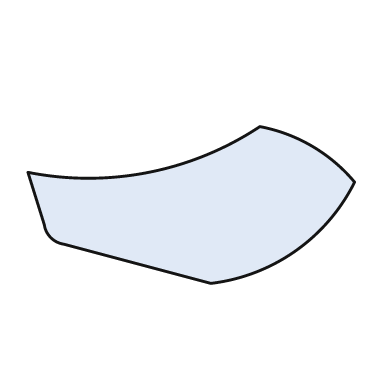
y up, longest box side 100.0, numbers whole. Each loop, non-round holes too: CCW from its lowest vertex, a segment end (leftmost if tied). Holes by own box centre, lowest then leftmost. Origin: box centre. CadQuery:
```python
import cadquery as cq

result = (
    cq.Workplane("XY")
    .moveTo(6.0, -24.0)
    .threePointArc((32.0, -14.0), (50.0, 7.0))
    .threePointArc((37.0, 18.0), (21.0, 24.0))
    .threePointArc((-13.0, 10.0), (-50.0, 10.0))
    .lineTo(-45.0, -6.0)
    .threePointArc((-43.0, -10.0), (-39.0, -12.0))
    .close()
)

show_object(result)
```